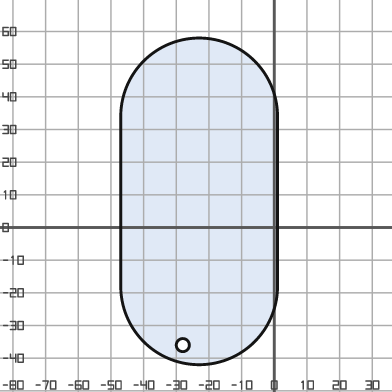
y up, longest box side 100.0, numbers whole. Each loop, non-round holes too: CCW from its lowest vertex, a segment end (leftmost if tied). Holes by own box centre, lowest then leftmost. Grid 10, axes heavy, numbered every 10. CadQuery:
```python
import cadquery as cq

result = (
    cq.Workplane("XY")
    .moveTo(-47.0, -18.0)
    .threePointArc((-23.0, -42.0), (1.0, -18.0))
    .lineTo(1.0, 34.0)
    .threePointArc((-23.0, 58.0), (-47.0, 34.0))
    .close()
    .moveTo(-28.0, -36.0)
    .circle(2.0)
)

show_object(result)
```